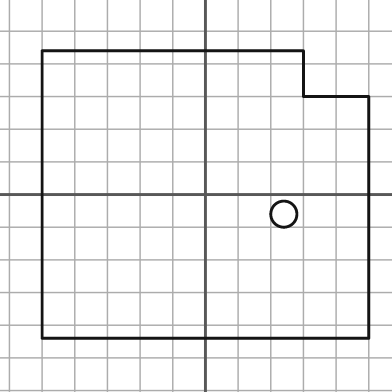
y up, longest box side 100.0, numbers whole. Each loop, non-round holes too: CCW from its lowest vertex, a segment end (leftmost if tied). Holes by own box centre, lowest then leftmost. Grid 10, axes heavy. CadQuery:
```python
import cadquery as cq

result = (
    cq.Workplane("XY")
    .moveTo(-50.0, -44.0)
    .lineTo(50.0, -44.0)
    .lineTo(50.0, 30.0)
    .lineTo(30.0, 30.0)
    .lineTo(30.0, 44.0)
    .lineTo(-50.0, 44.0)
    .close()
    .moveTo(24.0, -6.0)
    .circle(4.0)
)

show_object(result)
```